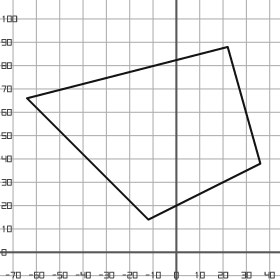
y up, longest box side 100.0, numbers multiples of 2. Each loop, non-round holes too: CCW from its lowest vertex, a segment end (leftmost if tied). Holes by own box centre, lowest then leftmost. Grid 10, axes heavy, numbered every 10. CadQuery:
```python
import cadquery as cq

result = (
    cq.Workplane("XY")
    .moveTo(-12.0, 14.0)
    .lineTo(36.0, 38.0)
    .lineTo(22.0, 88.0)
    .lineTo(-64.0, 66.0)
    .close()
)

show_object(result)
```